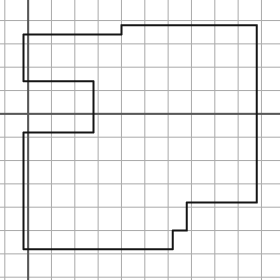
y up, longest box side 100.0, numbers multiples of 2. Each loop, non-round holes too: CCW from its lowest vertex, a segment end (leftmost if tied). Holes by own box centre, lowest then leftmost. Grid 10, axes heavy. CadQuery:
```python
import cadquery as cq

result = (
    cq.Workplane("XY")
    .moveTo(-2.0, -58.0)
    .lineTo(62.0, -58.0)
    .lineTo(62.0, -50.0)
    .lineTo(68.0, -50.0)
    .lineTo(68.0, -38.0)
    .lineTo(98.0, -38.0)
    .lineTo(98.0, 38.0)
    .lineTo(40.0, 38.0)
    .lineTo(40.0, 34.0)
    .lineTo(-2.0, 34.0)
    .lineTo(-2.0, 14.0)
    .lineTo(28.0, 14.0)
    .lineTo(28.0, -8.0)
    .lineTo(-2.0, -8.0)
    .close()
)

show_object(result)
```